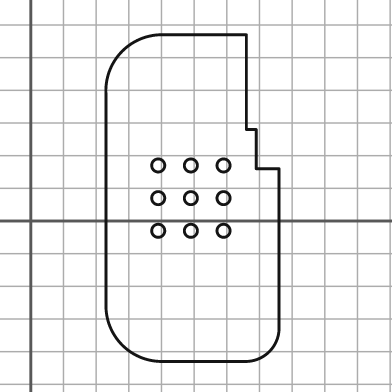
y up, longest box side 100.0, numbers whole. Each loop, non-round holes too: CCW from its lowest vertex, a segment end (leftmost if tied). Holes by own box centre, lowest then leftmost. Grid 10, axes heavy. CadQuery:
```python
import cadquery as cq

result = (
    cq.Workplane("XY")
    .moveTo(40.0, -43.0)
    .lineTo(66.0, -43.0)
    .threePointArc((73.0, -40.0), (76.0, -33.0))
    .lineTo(76.0, 16.0)
    .lineTo(69.0, 16.0)
    .lineTo(69.0, 28.0)
    .lineTo(66.0, 28.0)
    .lineTo(66.0, 57.0)
    .lineTo(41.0, 57.0)
    .threePointArc((28.0, 52.0), (23.0, 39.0))
    .lineTo(23.0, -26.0)
    .threePointArc((28.0, -38.0), (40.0, -43.0))
    .close()
    .moveTo(39.0, -3.0)
    .circle(2.0)
    .moveTo(49.0, -3.0)
    .circle(2.0)
    .moveTo(59.0, -3.0)
    .circle(2.0)
    .moveTo(39.0, 7.0)
    .circle(2.0)
    .moveTo(49.0, 7.0)
    .circle(2.0)
    .moveTo(59.0, 7.0)
    .circle(2.0)
    .moveTo(39.0, 17.0)
    .circle(2.0)
    .moveTo(49.0, 17.0)
    .circle(2.0)
    .moveTo(59.0, 17.0)
    .circle(2.0)
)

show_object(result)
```